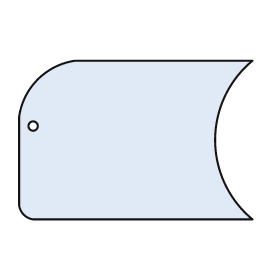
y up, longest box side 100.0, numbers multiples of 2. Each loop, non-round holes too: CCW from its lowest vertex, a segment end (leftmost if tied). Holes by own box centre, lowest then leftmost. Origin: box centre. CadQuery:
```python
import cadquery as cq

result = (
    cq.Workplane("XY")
    .moveTo(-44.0, -34.0)
    .lineTo(50.0, -34.0)
    .threePointArc((34.0, 0.0), (50.0, 34.0))
    .lineTo(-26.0, 34.0)
    .threePointArc((-42.0, 26.0), (-50.0, 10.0))
    .lineTo(-50.0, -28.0)
    .threePointArc((-48.0, -32.0), (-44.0, -34.0))
    .close()
    .moveTo(-44.0, 6.0)
    .circle(2.0)
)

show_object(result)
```